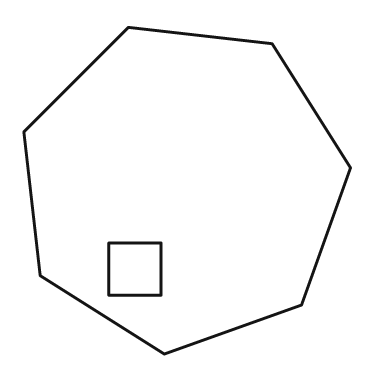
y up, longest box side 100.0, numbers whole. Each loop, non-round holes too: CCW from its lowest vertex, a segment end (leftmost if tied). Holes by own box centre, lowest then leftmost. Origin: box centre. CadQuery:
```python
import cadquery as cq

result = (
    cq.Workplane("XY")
    .moveTo(-7.0, -50.0)
    .lineTo(35.0, -35.0)
    .lineTo(50.0, 7.0)
    .lineTo(26.0, 45.0)
    .lineTo(-18.0, 50.0)
    .lineTo(-50.0, 18.0)
    .lineTo(-45.0, -26.0)
    .close()
    .moveTo(-24.0, -32.0)
    .lineTo(-8.0, -32.0)
    .lineTo(-8.0, -16.0)
    .lineTo(-24.0, -16.0)
    .close()
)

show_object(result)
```